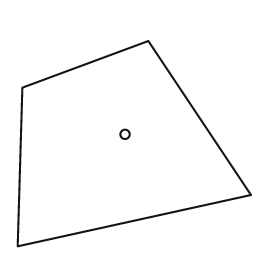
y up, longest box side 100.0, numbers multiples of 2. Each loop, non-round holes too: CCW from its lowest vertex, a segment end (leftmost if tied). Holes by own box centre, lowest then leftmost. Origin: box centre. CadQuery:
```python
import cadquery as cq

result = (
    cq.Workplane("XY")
    .moveTo(-50.0, -44.0)
    .lineTo(50.0, -22.0)
    .lineTo(6.0, 44.0)
    .lineTo(-48.0, 24.0)
    .close()
    .moveTo(-4.0, 4.0)
    .circle(2.0)
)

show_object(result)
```